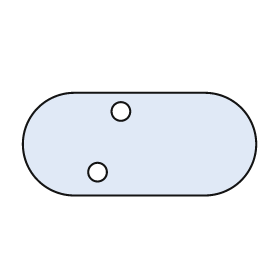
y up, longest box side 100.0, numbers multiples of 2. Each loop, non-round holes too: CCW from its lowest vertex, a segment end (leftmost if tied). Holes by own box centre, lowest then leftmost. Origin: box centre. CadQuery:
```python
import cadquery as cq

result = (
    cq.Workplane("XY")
    .moveTo(-28.0, -22.0)
    .lineTo(28.0, -22.0)
    .threePointArc((50.0, 0.0), (28.0, 22.0))
    .lineTo(-28.0, 22.0)
    .threePointArc((-50.0, 0.0), (-28.0, -22.0))
    .close()
    .moveTo(-18.0, -12.0)
    .circle(4.0)
    .moveTo(-8.0, 14.0)
    .circle(4.0)
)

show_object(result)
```